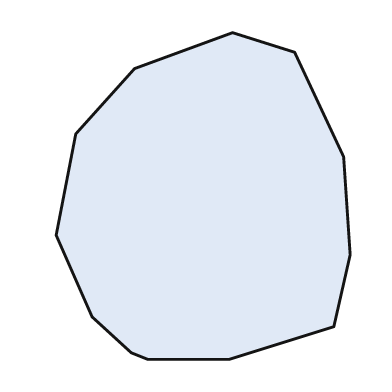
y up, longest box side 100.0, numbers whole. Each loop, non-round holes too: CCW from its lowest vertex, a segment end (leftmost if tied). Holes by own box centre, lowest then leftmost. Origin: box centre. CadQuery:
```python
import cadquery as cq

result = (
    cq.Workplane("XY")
    .moveTo(-17.0, -50.0)
    .lineTo(8.0, -50.0)
    .lineTo(40.0, -40.0)
    .lineTo(45.0, -18.0)
    .lineTo(43.0, 12.0)
    .lineTo(28.0, 44.0)
    .lineTo(9.0, 50.0)
    .lineTo(-21.0, 39.0)
    .lineTo(-39.0, 19.0)
    .lineTo(-45.0, -12.0)
    .lineTo(-34.0, -37.0)
    .lineTo(-22.0, -48.0)
    .close()
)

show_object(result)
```